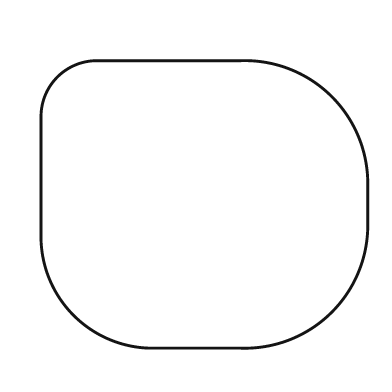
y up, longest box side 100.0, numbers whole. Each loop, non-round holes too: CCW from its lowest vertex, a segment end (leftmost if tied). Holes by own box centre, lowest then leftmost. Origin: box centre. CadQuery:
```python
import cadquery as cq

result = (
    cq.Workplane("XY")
    .moveTo(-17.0, -44.0)
    .lineTo(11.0, -44.0)
    .threePointArc((39.0, -33.0), (50.0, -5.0))
    .lineTo(50.0, 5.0)
    .threePointArc((39.0, 33.0), (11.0, 44.0))
    .lineTo(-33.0, 44.0)
    .threePointArc((-45.0, 39.0), (-50.0, 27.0))
    .lineTo(-50.0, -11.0)
    .threePointArc((-40.0, -34.0), (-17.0, -44.0))
    .close()
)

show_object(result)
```